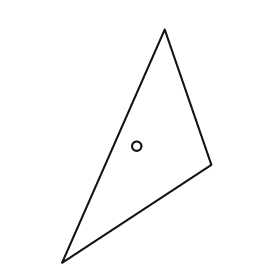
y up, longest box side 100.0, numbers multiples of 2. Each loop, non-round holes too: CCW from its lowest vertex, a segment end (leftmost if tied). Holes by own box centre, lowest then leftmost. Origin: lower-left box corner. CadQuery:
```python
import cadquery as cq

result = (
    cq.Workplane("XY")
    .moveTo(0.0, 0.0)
    .lineTo(64.0, 42.0)
    .lineTo(44.0, 100.0)
    .close()
    .moveTo(32.0, 50.0)
    .circle(2.0)
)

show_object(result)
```